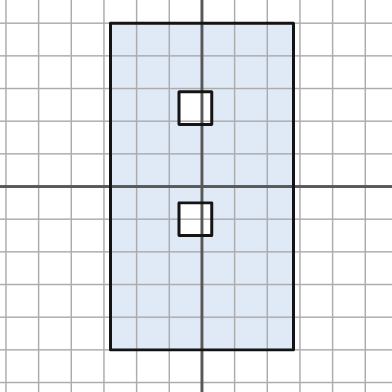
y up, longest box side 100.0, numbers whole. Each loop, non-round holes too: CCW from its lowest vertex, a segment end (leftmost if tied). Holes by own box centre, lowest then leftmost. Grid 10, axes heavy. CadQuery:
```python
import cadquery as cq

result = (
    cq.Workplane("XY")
    .moveTo(-28.0, -50.0)
    .lineTo(28.0, -50.0)
    .lineTo(28.0, 50.0)
    .lineTo(-28.0, 50.0)
    .close()
    .moveTo(-7.0, -15.0)
    .lineTo(3.0, -15.0)
    .lineTo(3.0, -5.0)
    .lineTo(-7.0, -5.0)
    .close()
    .moveTo(-7.0, 19.0)
    .lineTo(3.0, 19.0)
    .lineTo(3.0, 29.0)
    .lineTo(-7.0, 29.0)
    .close()
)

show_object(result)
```